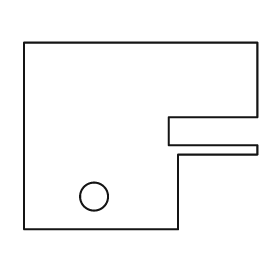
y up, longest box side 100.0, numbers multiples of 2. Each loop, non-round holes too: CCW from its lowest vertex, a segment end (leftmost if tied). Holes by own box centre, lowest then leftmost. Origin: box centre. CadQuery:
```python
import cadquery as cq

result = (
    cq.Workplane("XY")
    .moveTo(-50.0, -40.0)
    .lineTo(16.0, -40.0)
    .lineTo(16.0, -8.0)
    .lineTo(50.0, -8.0)
    .lineTo(50.0, -4.0)
    .lineTo(12.0, -4.0)
    .lineTo(12.0, 8.0)
    .lineTo(50.0, 8.0)
    .lineTo(50.0, 40.0)
    .lineTo(-50.0, 40.0)
    .close()
    .moveTo(-20.0, -26.0)
    .circle(6.0)
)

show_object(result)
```